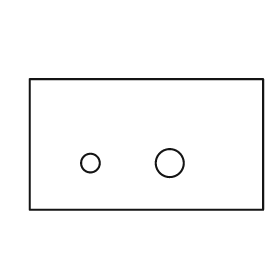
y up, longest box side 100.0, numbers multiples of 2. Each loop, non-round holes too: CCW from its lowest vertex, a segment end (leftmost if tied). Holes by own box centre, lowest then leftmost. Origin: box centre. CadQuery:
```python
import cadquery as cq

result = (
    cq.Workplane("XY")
    .moveTo(-50.0, -28.0)
    .lineTo(50.0, -28.0)
    .lineTo(50.0, 28.0)
    .lineTo(-50.0, 28.0)
    .close()
    .moveTo(-24.0, -8.0)
    .circle(4.0)
    .moveTo(10.0, -8.0)
    .circle(6.0)
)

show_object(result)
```